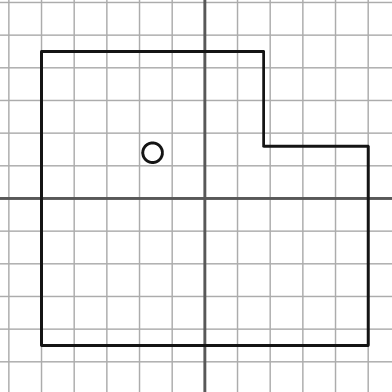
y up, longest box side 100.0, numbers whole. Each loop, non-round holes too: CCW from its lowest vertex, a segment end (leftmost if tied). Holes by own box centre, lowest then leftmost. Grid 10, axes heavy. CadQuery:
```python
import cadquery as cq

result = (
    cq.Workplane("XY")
    .moveTo(-50.0, -45.0)
    .lineTo(50.0, -45.0)
    .lineTo(50.0, 16.0)
    .lineTo(18.0, 16.0)
    .lineTo(18.0, 45.0)
    .lineTo(-50.0, 45.0)
    .close()
    .moveTo(-16.0, 14.0)
    .circle(3.0)
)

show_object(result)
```